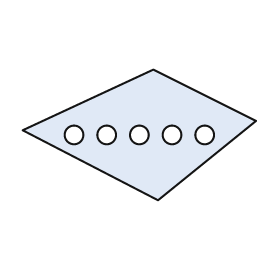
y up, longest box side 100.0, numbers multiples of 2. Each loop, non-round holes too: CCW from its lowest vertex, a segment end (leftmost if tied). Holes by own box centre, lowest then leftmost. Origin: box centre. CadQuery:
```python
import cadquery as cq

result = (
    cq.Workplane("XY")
    .moveTo(8.0, -28.0)
    .lineTo(50.0, 6.0)
    .lineTo(6.0, 28.0)
    .lineTo(-50.0, 2.0)
    .close()
    .moveTo(-28.0, 0.0)
    .circle(4.0)
    .moveTo(-14.0, 0.0)
    .circle(4.0)
    .moveTo(0.0, 0.0)
    .circle(4.0)
    .moveTo(14.0, 0.0)
    .circle(4.0)
    .moveTo(28.0, 0.0)
    .circle(4.0)
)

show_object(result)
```